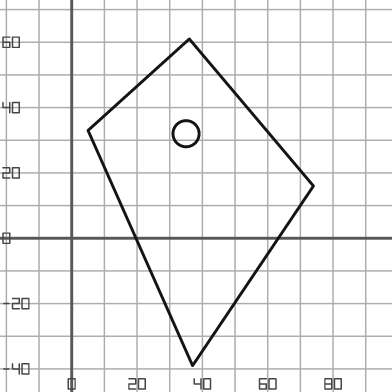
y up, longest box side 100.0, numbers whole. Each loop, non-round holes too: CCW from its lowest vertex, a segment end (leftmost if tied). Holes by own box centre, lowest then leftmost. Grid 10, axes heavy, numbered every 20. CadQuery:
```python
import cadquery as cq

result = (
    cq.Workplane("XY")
    .moveTo(37.0, -39.0)
    .lineTo(74.0, 16.0)
    .lineTo(36.0, 61.0)
    .lineTo(5.0, 33.0)
    .close()
    .moveTo(35.0, 32.0)
    .circle(4.0)
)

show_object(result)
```